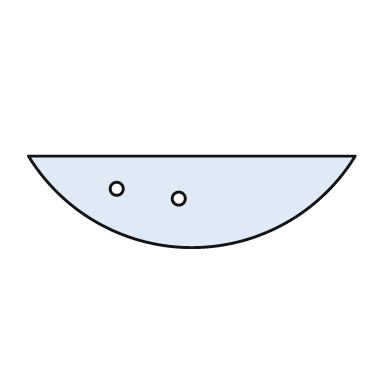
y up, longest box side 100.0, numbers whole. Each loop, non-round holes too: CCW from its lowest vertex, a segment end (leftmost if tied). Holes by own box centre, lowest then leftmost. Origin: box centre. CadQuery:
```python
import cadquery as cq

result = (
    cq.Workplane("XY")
    .moveTo(-50.0, 14.0)
    .threePointArc((0.0, -14.0), (50.0, 14.0))
    .close()
    .moveTo(-4.0, 1.0)
    .circle(2.0)
    .moveTo(-23.0, 4.0)
    .circle(2.0)
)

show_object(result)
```